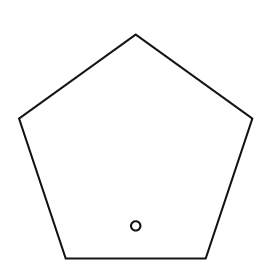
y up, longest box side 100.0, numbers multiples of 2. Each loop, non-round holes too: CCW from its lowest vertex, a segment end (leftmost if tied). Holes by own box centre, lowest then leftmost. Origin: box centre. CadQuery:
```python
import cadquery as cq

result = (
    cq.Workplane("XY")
    .moveTo(-30.0, -48.0)
    .lineTo(30.0, -48.0)
    .lineTo(50.0, 12.0)
    .lineTo(0.0, 48.0)
    .lineTo(-50.0, 12.0)
    .close()
    .moveTo(0.0, -34.0)
    .circle(2.0)
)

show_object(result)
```